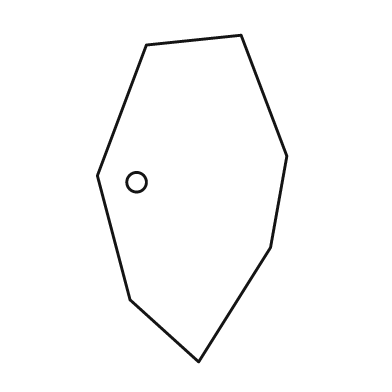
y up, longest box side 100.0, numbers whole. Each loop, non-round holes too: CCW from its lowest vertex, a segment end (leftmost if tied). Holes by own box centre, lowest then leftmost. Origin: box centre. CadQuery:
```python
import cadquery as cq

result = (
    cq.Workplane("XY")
    .moveTo(2.0, -50.0)
    .lineTo(24.0, -15.0)
    .lineTo(29.0, 13.0)
    .lineTo(15.0, 50.0)
    .lineTo(-14.0, 47.0)
    .lineTo(-29.0, 7.0)
    .lineTo(-19.0, -31.0)
    .close()
    .moveTo(-17.0, 5.0)
    .circle(3.0)
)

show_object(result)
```